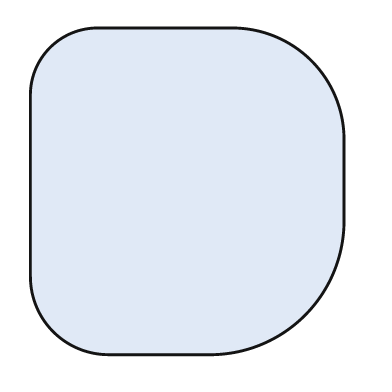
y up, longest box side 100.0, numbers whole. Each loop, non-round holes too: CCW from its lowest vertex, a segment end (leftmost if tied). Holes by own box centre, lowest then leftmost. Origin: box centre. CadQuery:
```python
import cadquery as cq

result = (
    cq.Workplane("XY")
    .moveTo(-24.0, -50.0)
    .lineTo(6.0, -50.0)
    .threePointArc((36.0, -38.0), (48.0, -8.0))
    .lineTo(48.0, 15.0)
    .threePointArc((38.0, 40.0), (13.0, 50.0))
    .lineTo(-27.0, 50.0)
    .threePointArc((-42.0, 44.0), (-48.0, 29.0))
    .lineTo(-48.0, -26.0)
    .threePointArc((-41.0, -43.0), (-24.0, -50.0))
    .close()
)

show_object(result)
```